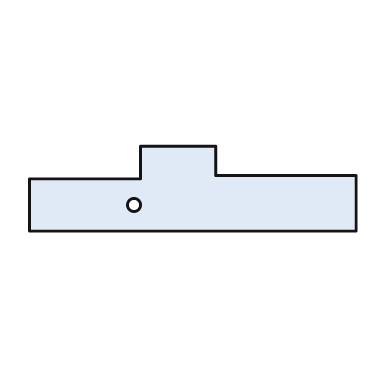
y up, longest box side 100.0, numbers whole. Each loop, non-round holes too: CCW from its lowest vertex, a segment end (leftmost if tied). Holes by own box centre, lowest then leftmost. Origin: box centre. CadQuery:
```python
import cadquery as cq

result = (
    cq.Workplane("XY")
    .moveTo(-50.0, -13.0)
    .lineTo(50.0, -13.0)
    .lineTo(50.0, 4.0)
    .lineTo(7.0, 4.0)
    .lineTo(7.0, 13.0)
    .lineTo(-16.0, 13.0)
    .lineTo(-16.0, 3.0)
    .lineTo(-50.0, 3.0)
    .close()
    .moveTo(-18.0, -5.0)
    .circle(2.0)
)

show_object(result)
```